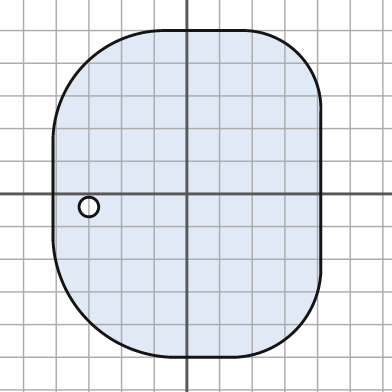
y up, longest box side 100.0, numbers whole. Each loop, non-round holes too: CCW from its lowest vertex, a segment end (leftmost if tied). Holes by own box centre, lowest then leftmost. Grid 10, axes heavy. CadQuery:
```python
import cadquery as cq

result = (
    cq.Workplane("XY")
    .moveTo(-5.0, -50.0)
    .lineTo(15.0, -50.0)
    .threePointArc((33.0, -42.0), (41.0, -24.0))
    .lineTo(41.0, 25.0)
    .threePointArc((34.0, 43.0), (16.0, 50.0))
    .lineTo(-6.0, 50.0)
    .threePointArc((-31.0, 40.0), (-41.0, 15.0))
    .lineTo(-41.0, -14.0)
    .threePointArc((-30.0, -39.0), (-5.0, -50.0))
    .close()
    .moveTo(-30.0, -4.0)
    .circle(3.0)
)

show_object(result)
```